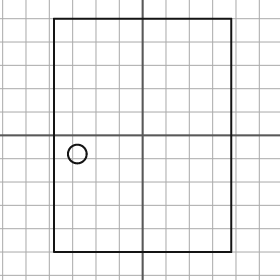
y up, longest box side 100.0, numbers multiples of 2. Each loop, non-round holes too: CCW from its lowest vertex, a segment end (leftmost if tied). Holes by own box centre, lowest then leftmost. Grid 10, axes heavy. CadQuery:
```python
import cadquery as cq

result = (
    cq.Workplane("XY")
    .moveTo(-38.0, -50.0)
    .lineTo(38.0, -50.0)
    .lineTo(38.0, 50.0)
    .lineTo(-38.0, 50.0)
    .close()
    .moveTo(-28.0, -8.0)
    .circle(4.0)
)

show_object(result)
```